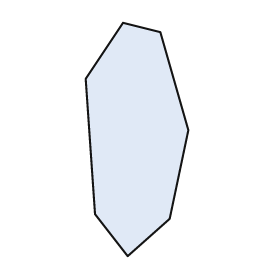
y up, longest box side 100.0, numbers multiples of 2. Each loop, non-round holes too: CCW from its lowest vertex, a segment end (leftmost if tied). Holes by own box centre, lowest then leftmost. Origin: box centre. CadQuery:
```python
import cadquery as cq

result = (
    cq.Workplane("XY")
    .moveTo(-4.0, -50.0)
    .lineTo(14.0, -34.0)
    .lineTo(22.0, 4.0)
    .lineTo(10.0, 46.0)
    .lineTo(-6.0, 50.0)
    .lineTo(-22.0, 26.0)
    .lineTo(-18.0, -32.0)
    .close()
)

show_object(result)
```